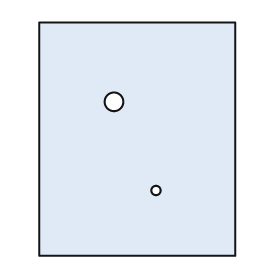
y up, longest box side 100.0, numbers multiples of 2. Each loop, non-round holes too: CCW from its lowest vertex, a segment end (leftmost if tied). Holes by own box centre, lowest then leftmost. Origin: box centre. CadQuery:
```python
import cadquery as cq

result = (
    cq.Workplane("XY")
    .moveTo(-42.0, -50.0)
    .lineTo(42.0, -50.0)
    .lineTo(42.0, 50.0)
    .lineTo(-42.0, 50.0)
    .close()
    .moveTo(8.0, -22.0)
    .circle(2.0)
    .moveTo(-10.0, 16.0)
    .circle(4.0)
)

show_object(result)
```